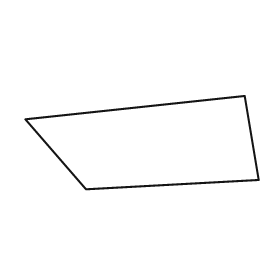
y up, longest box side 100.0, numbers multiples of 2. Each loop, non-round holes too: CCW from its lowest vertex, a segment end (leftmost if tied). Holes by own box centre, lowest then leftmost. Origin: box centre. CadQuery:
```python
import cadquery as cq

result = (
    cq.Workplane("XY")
    .moveTo(-24.0, -20.0)
    .lineTo(50.0, -16.0)
    .lineTo(44.0, 20.0)
    .lineTo(-50.0, 10.0)
    .close()
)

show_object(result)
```